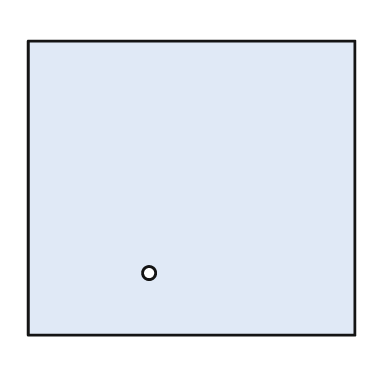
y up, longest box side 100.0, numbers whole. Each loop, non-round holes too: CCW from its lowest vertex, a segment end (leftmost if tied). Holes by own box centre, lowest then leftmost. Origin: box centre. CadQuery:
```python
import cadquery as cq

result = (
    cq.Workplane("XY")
    .moveTo(-50.0, -45.0)
    .lineTo(50.0, -45.0)
    .lineTo(50.0, 45.0)
    .lineTo(-50.0, 45.0)
    .close()
    .moveTo(-13.0, -26.0)
    .circle(2.0)
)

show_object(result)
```